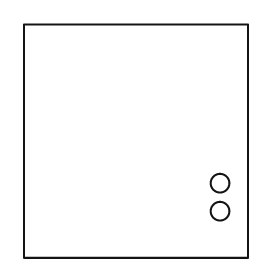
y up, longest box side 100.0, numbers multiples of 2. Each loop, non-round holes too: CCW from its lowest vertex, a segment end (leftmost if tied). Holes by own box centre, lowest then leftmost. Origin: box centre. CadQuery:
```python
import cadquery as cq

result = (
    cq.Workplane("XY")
    .moveTo(-48.0, -50.0)
    .lineTo(48.0, -50.0)
    .lineTo(48.0, 50.0)
    .lineTo(-48.0, 50.0)
    .close()
    .moveTo(36.0, -30.0)
    .circle(4.0)
    .moveTo(36.0, -18.0)
    .circle(4.0)
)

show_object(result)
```